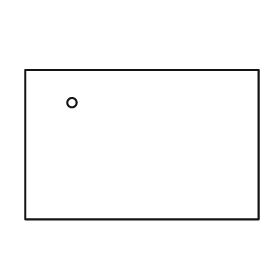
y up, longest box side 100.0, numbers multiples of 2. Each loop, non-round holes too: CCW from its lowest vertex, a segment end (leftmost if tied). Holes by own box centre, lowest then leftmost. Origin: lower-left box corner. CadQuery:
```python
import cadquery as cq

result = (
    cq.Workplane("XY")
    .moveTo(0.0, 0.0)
    .lineTo(100.0, 0.0)
    .lineTo(100.0, 64.0)
    .lineTo(0.0, 64.0)
    .close()
    .moveTo(20.0, 50.0)
    .circle(2.0)
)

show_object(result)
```